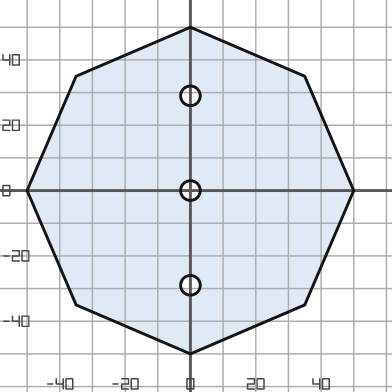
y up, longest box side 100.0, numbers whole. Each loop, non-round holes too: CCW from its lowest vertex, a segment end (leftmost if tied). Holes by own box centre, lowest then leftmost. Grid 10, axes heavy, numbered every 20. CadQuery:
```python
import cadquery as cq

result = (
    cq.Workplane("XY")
    .moveTo(0.0, -50.0)
    .lineTo(35.0, -35.0)
    .lineTo(50.0, 0.0)
    .lineTo(35.0, 35.0)
    .lineTo(0.0, 50.0)
    .lineTo(-35.0, 35.0)
    .lineTo(-50.0, 0.0)
    .lineTo(-35.0, -35.0)
    .close()
    .moveTo(0.0, -29.0)
    .circle(3.0)
    .moveTo(0.0, 0.0)
    .circle(3.0)
    .moveTo(0.0, 29.0)
    .circle(3.0)
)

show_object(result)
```